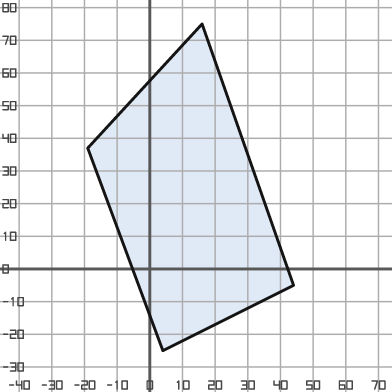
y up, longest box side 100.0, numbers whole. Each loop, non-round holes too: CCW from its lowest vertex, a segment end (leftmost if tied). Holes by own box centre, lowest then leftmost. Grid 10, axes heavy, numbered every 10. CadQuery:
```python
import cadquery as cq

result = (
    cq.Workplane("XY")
    .moveTo(4.0, -25.0)
    .lineTo(44.0, -5.0)
    .lineTo(16.0, 75.0)
    .lineTo(-19.0, 37.0)
    .close()
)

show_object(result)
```